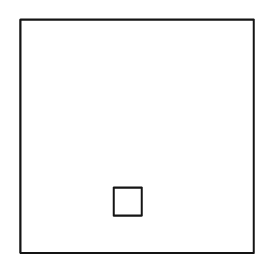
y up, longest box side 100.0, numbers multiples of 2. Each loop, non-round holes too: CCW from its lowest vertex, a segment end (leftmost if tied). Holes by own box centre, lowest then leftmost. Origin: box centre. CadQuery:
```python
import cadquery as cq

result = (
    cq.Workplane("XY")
    .moveTo(-50.0, -50.0)
    .lineTo(50.0, -50.0)
    .lineTo(50.0, 50.0)
    .lineTo(-50.0, 50.0)
    .close()
    .moveTo(-10.0, -34.0)
    .lineTo(2.0, -34.0)
    .lineTo(2.0, -22.0)
    .lineTo(-10.0, -22.0)
    .close()
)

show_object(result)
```